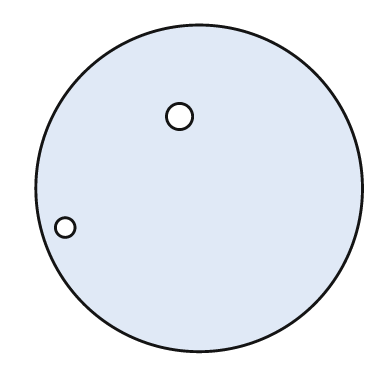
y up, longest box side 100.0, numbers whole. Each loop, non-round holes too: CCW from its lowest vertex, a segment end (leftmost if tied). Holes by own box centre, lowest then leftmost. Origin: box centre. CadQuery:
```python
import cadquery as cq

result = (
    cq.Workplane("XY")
    .moveTo(0.0, 0.0)
    .circle(50.0)
    .moveTo(-41.0, -12.0)
    .circle(3.0)
    .moveTo(-6.0, 22.0)
    .circle(4.0)
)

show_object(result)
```